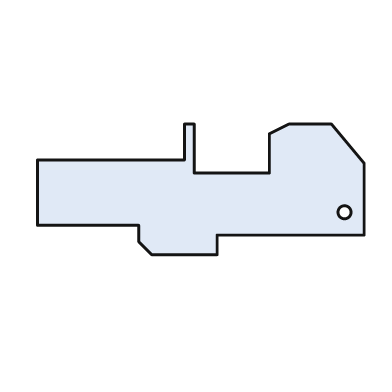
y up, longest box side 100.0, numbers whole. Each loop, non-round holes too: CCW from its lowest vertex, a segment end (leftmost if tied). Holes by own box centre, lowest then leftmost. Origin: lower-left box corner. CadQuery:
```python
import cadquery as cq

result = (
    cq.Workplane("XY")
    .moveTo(35.0, 0.0)
    .lineTo(55.0, 0.0)
    .lineTo(55.0, 6.0)
    .lineTo(100.0, 6.0)
    .lineTo(100.0, 28.0)
    .lineTo(90.0, 40.0)
    .lineTo(77.0, 40.0)
    .lineTo(71.0, 37.0)
    .lineTo(71.0, 25.0)
    .lineTo(48.0, 25.0)
    .lineTo(48.0, 40.0)
    .lineTo(45.0, 40.0)
    .lineTo(45.0, 29.0)
    .lineTo(0.0, 29.0)
    .lineTo(0.0, 9.0)
    .lineTo(31.0, 9.0)
    .lineTo(31.0, 4.0)
    .close()
    .moveTo(94.0, 13.0)
    .circle(2.0)
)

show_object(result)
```